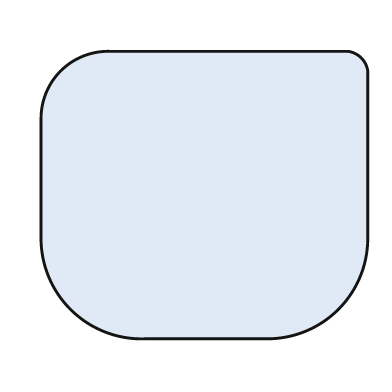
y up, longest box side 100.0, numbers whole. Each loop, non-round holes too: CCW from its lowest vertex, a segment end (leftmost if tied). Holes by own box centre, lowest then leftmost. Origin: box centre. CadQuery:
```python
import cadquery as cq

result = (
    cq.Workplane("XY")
    .moveTo(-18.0, -44.0)
    .lineTo(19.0, -44.0)
    .threePointArc((41.0, -35.0), (50.0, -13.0))
    .lineTo(50.0, 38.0)
    .threePointArc((48.0, 42.0), (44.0, 44.0))
    .lineTo(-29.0, 44.0)
    .threePointArc((-44.0, 38.0), (-50.0, 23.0))
    .lineTo(-50.0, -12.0)
    .threePointArc((-41.0, -35.0), (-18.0, -44.0))
    .close()
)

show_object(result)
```